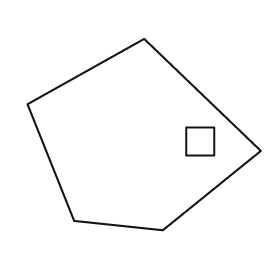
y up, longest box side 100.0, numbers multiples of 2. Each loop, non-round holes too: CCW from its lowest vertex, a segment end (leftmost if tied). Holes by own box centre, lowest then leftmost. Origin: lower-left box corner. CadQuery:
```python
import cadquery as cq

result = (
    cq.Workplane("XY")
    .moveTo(58.0, 0.0)
    .lineTo(100.0, 34.0)
    .lineTo(50.0, 82.0)
    .lineTo(0.0, 54.0)
    .lineTo(20.0, 4.0)
    .close()
    .moveTo(68.0, 32.0)
    .lineTo(80.0, 32.0)
    .lineTo(80.0, 44.0)
    .lineTo(68.0, 44.0)
    .close()
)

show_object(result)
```